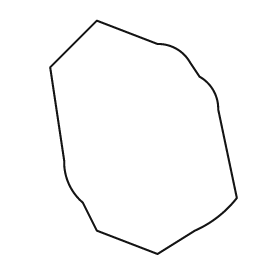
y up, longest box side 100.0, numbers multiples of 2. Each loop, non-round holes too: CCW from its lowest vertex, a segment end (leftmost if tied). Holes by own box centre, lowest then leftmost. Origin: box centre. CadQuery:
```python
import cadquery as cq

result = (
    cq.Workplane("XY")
    .moveTo(6.0, -50.0)
    .lineTo(22.0, -40.0)
    .threePointArc((32.0, -34.0), (40.0, -26.0))
    .lineTo(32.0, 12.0)
    .threePointArc((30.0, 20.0), (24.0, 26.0))
    .lineTo(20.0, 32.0)
    .threePointArc((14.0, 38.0), (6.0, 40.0))
    .lineTo(-20.0, 50.0)
    .lineTo(-40.0, 30.0)
    .lineTo(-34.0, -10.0)
    .threePointArc((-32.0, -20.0), (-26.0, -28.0))
    .lineTo(-20.0, -40.0)
    .close()
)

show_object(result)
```